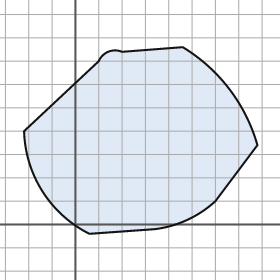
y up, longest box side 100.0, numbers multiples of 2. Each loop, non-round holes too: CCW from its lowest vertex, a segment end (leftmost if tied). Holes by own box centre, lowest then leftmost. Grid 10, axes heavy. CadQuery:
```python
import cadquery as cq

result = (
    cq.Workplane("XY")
    .moveTo(6.0, -4.0)
    .lineTo(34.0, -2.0)
    .threePointArc((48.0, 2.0), (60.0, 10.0))
    .lineTo(78.0, 34.0)
    .threePointArc((66.0, 58.0), (46.0, 76.0))
    .lineTo(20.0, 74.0)
    .threePointArc((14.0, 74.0), (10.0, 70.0))
    .lineTo(-22.0, 40.0)
    .threePointArc((-14.0, 14.0), (6.0, -4.0))
    .close()
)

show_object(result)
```